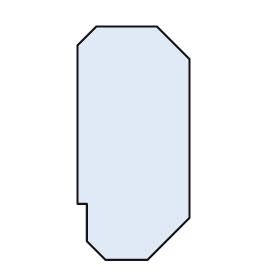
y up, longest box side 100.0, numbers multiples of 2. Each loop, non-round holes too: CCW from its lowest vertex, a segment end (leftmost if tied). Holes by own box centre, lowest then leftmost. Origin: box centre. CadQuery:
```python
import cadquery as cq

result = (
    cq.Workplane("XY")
    .moveTo(-12.0, -50.0)
    .lineTo(6.0, -50.0)
    .lineTo(24.0, -32.0)
    .lineTo(24.0, 36.0)
    .lineTo(10.0, 50.0)
    .lineTo(-16.0, 50.0)
    .lineTo(-24.0, 42.0)
    .lineTo(-24.0, -26.0)
    .lineTo(-20.0, -26.0)
    .lineTo(-20.0, -42.0)
    .close()
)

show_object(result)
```